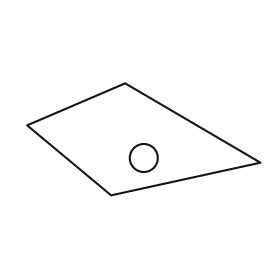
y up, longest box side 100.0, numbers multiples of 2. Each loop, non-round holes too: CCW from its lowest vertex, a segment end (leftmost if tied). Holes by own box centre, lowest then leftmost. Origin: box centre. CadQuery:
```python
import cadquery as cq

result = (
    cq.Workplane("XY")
    .moveTo(-14.0, -24.0)
    .lineTo(50.0, -10.0)
    .lineTo(-8.0, 24.0)
    .lineTo(-50.0, 6.0)
    .close()
    .moveTo(0.0, -8.0)
    .circle(6.0)
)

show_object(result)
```